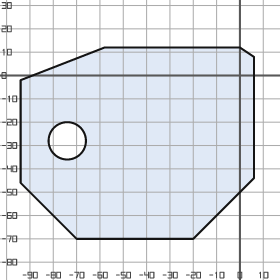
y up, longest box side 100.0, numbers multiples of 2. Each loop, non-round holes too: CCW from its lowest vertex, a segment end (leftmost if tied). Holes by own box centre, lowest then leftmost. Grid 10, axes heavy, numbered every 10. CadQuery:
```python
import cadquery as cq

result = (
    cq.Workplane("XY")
    .moveTo(-70.0, -70.0)
    .lineTo(-20.0, -70.0)
    .lineTo(6.0, -44.0)
    .lineTo(6.0, 8.0)
    .lineTo(0.0, 12.0)
    .lineTo(-58.0, 12.0)
    .lineTo(-94.0, -2.0)
    .lineTo(-94.0, -46.0)
    .close()
    .moveTo(-74.0, -28.0)
    .circle(8.0)
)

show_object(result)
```